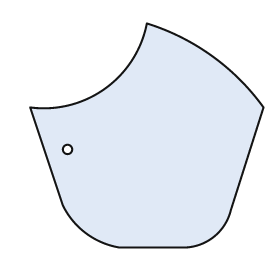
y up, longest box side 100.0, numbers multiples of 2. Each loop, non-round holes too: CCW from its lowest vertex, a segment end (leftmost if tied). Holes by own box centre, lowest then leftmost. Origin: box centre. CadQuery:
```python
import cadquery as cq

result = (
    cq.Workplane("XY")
    .moveTo(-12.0, -48.0)
    .lineTo(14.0, -48.0)
    .threePointArc((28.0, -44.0), (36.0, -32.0))
    .lineTo(50.0, 12.0)
    .threePointArc((28.0, 34.0), (0.0, 48.0))
    .threePointArc((-18.0, 20.0), (-50.0, 12.0))
    .lineTo(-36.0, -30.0)
    .threePointArc((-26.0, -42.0), (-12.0, -48.0))
    .close()
    .moveTo(-34.0, -6.0)
    .circle(2.0)
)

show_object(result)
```